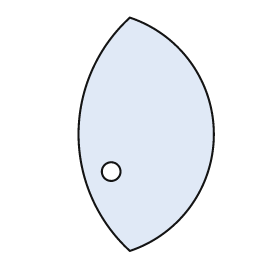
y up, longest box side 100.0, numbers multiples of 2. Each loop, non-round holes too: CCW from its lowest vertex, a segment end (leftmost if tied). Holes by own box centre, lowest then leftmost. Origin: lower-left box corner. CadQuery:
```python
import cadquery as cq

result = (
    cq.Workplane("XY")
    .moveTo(22.0, 0.0)
    .threePointArc((58.0, 50.0), (22.0, 100.0))
    .threePointArc((0.0, 50.0), (22.0, 0.0))
    .close()
    .moveTo(14.0, 34.0)
    .circle(4.0)
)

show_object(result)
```